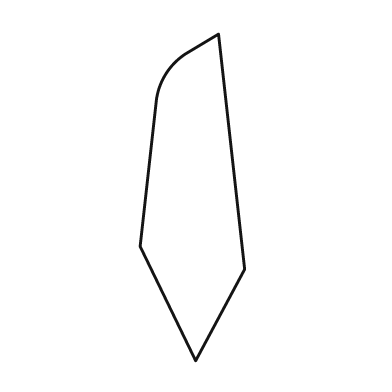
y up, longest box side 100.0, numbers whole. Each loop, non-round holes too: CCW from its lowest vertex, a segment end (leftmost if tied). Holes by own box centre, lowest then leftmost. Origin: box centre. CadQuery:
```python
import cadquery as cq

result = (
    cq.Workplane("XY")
    .moveTo(1.0, -50.0)
    .lineTo(16.0, -22.0)
    .lineTo(8.0, 50.0)
    .lineTo(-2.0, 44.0)
    .threePointArc((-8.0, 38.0), (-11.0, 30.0))
    .lineTo(-16.0, -15.0)
    .close()
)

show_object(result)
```